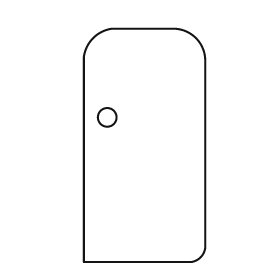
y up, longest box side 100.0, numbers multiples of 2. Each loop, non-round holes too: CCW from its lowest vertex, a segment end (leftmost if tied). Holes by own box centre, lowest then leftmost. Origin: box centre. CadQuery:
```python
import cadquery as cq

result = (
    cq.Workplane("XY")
    .moveTo(-26.0, -50.0)
    .lineTo(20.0, -50.0)
    .threePointArc((24.0, -48.0), (26.0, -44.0))
    .lineTo(26.0, 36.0)
    .threePointArc((22.0, 46.0), (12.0, 50.0))
    .lineTo(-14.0, 50.0)
    .threePointArc((-22.0, 46.0), (-26.0, 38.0))
    .close()
    .moveTo(-16.0, 12.0)
    .circle(4.0)
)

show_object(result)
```